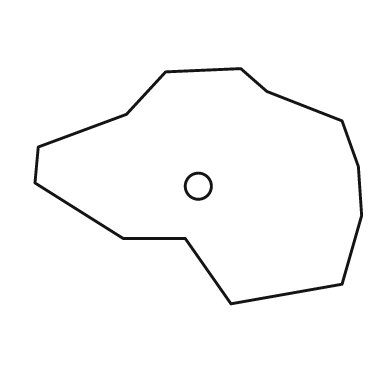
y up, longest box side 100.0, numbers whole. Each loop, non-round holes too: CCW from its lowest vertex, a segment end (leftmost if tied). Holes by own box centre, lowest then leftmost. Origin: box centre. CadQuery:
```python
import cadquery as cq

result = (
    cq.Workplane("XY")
    .moveTo(10.0, -36.0)
    .lineTo(44.0, -30.0)
    .lineTo(50.0, -9.0)
    .lineTo(49.0, 6.0)
    .lineTo(44.0, 20.0)
    .lineTo(21.0, 29.0)
    .lineTo(13.0, 36.0)
    .lineTo(-10.0, 35.0)
    .lineTo(-22.0, 22.0)
    .lineTo(-49.0, 12.0)
    .lineTo(-50.0, 1.0)
    .lineTo(-23.0, -16.0)
    .lineTo(-4.0, -16.0)
    .close()
    .moveTo(0.0, 0.0)
    .circle(4.0)
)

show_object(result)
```